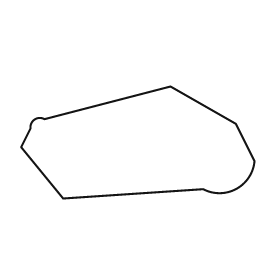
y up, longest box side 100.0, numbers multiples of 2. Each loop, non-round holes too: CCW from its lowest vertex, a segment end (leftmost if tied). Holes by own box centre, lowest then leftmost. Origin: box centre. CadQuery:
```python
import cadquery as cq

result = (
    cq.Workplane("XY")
    .moveTo(-32.0, -24.0)
    .lineTo(28.0, -20.0)
    .threePointArc((42.0, -20.0), (50.0, -8.0))
    .lineTo(42.0, 8.0)
    .lineTo(14.0, 24.0)
    .lineTo(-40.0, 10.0)
    .threePointArc((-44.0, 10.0), (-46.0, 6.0))
    .lineTo(-50.0, -2.0)
    .close()
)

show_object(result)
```